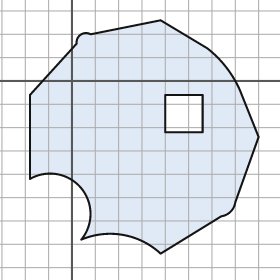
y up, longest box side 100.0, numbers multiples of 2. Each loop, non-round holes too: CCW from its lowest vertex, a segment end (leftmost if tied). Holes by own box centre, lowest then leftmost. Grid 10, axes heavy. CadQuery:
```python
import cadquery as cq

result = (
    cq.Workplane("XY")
    .moveTo(38.0, -74.0)
    .lineTo(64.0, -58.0)
    .threePointArc((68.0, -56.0), (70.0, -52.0))
    .lineTo(80.0, -24.0)
    .lineTo(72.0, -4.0)
    .threePointArc((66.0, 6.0), (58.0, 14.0))
    .lineTo(38.0, 26.0)
    .lineTo(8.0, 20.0)
    .threePointArc((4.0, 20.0), (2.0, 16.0))
    .lineTo(-18.0, -6.0)
    .lineTo(-18.0, -42.0)
    .threePointArc((4.0, -46.0), (4.0, -68.0))
    .threePointArc((22.0, -66.0), (38.0, -74.0))
    .close()
    .moveTo(40.0, -22.0)
    .lineTo(56.0, -22.0)
    .lineTo(56.0, -6.0)
    .lineTo(40.0, -6.0)
    .close()
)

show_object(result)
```